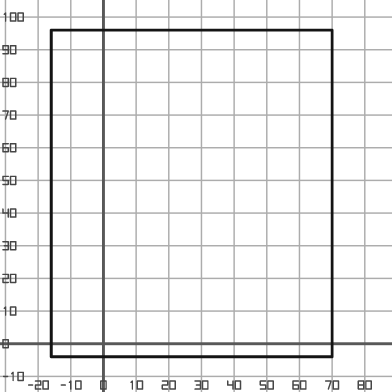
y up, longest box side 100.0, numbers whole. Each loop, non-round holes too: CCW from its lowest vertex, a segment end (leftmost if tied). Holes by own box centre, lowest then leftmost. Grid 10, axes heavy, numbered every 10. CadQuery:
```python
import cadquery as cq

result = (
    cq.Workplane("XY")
    .moveTo(-16.0, -4.0)
    .lineTo(70.0, -4.0)
    .lineTo(70.0, 96.0)
    .lineTo(-16.0, 96.0)
    .close()
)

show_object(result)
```